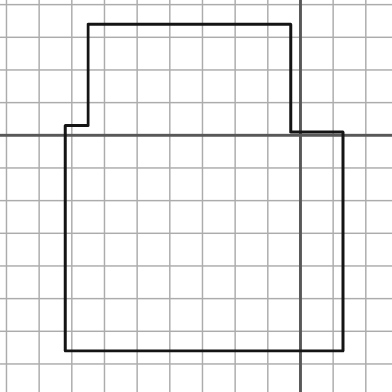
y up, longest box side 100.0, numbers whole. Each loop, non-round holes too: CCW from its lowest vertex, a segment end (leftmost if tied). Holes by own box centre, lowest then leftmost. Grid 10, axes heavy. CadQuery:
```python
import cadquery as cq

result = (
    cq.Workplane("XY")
    .moveTo(-72.0, -66.0)
    .lineTo(13.0, -66.0)
    .lineTo(13.0, 1.0)
    .lineTo(-3.0, 1.0)
    .lineTo(-3.0, 34.0)
    .lineTo(-65.0, 34.0)
    .lineTo(-65.0, 3.0)
    .lineTo(-72.0, 3.0)
    .close()
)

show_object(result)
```